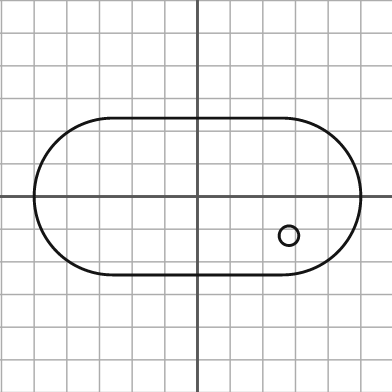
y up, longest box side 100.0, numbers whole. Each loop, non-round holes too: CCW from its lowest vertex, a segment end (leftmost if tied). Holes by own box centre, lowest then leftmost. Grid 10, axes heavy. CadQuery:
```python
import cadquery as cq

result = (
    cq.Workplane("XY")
    .moveTo(-26.0, -24.0)
    .lineTo(26.0, -24.0)
    .threePointArc((50.0, 0.0), (26.0, 24.0))
    .lineTo(-26.0, 24.0)
    .threePointArc((-50.0, 0.0), (-26.0, -24.0))
    .close()
    .moveTo(28.0, -12.0)
    .circle(3.0)
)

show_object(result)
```